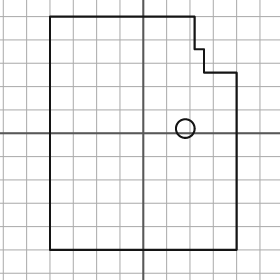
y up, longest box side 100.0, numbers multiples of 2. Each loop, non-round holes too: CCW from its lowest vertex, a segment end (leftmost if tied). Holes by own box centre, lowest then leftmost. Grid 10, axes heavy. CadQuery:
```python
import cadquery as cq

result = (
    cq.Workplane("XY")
    .moveTo(-40.0, -50.0)
    .lineTo(40.0, -50.0)
    .lineTo(40.0, 26.0)
    .lineTo(26.0, 26.0)
    .lineTo(26.0, 36.0)
    .lineTo(22.0, 36.0)
    .lineTo(22.0, 50.0)
    .lineTo(-40.0, 50.0)
    .close()
    .moveTo(18.0, 2.0)
    .circle(4.0)
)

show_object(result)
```